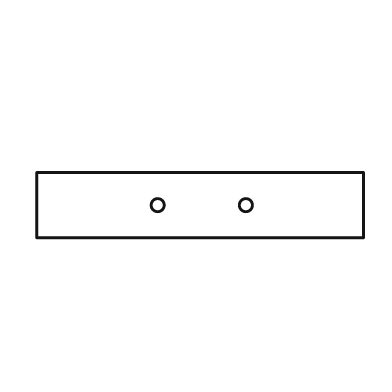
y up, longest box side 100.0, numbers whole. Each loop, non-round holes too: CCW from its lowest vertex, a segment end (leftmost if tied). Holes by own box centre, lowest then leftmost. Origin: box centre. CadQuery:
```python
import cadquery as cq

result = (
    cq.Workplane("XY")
    .moveTo(-50.0, -10.0)
    .lineTo(50.0, -10.0)
    .lineTo(50.0, 10.0)
    .lineTo(-50.0, 10.0)
    .close()
    .moveTo(-13.0, 0.0)
    .circle(2.0)
    .moveTo(14.0, 0.0)
    .circle(2.0)
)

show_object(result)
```